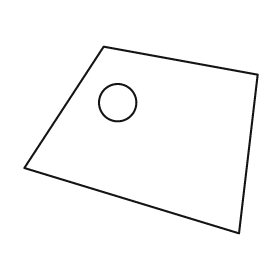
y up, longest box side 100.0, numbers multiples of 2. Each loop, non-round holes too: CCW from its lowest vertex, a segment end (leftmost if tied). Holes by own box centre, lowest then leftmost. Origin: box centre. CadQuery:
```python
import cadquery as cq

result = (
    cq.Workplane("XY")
    .moveTo(42.0, -40.0)
    .lineTo(50.0, 28.0)
    .lineTo(-16.0, 40.0)
    .lineTo(-50.0, -12.0)
    .close()
    .moveTo(-10.0, 16.0)
    .circle(8.0)
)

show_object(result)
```